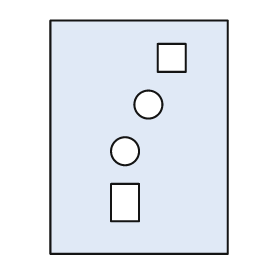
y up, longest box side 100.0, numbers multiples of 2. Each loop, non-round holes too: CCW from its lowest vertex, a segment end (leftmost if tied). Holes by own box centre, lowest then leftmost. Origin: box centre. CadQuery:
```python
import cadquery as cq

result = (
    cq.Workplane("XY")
    .moveTo(-38.0, -50.0)
    .lineTo(38.0, -50.0)
    .lineTo(38.0, 50.0)
    .lineTo(-38.0, 50.0)
    .close()
    .moveTo(-12.0, -36.0)
    .lineTo(0.0, -36.0)
    .lineTo(0.0, -20.0)
    .lineTo(-12.0, -20.0)
    .close()
    .moveTo(-6.0, -6.0)
    .circle(6.0)
    .moveTo(4.0, 14.0)
    .circle(6.0)
    .moveTo(8.0, 28.0)
    .lineTo(20.0, 28.0)
    .lineTo(20.0, 40.0)
    .lineTo(8.0, 40.0)
    .close()
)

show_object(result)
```